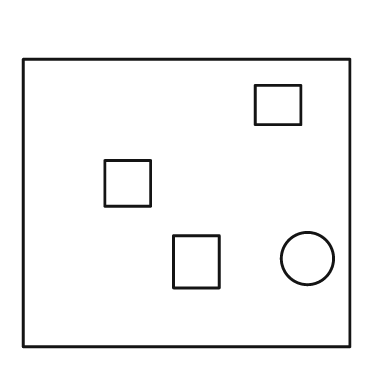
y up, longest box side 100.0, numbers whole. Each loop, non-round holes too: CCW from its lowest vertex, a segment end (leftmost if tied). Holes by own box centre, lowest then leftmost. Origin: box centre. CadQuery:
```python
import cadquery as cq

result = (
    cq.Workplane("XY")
    .moveTo(-50.0, -44.0)
    .lineTo(50.0, -44.0)
    .lineTo(50.0, 44.0)
    .lineTo(-50.0, 44.0)
    .close()
    .moveTo(-4.0, -26.0)
    .lineTo(10.0, -26.0)
    .lineTo(10.0, -10.0)
    .lineTo(-4.0, -10.0)
    .close()
    .moveTo(37.0, -17.0)
    .circle(8.0)
    .moveTo(-25.0, -1.0)
    .lineTo(-11.0, -1.0)
    .lineTo(-11.0, 13.0)
    .lineTo(-25.0, 13.0)
    .close()
    .moveTo(21.0, 24.0)
    .lineTo(35.0, 24.0)
    .lineTo(35.0, 36.0)
    .lineTo(21.0, 36.0)
    .close()
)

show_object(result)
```